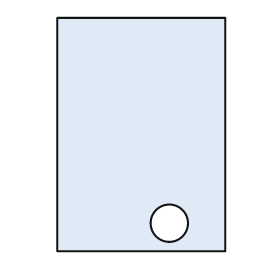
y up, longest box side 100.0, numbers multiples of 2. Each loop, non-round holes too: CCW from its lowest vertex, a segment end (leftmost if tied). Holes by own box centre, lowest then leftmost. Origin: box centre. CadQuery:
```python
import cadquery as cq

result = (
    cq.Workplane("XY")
    .moveTo(-36.0, -50.0)
    .lineTo(36.0, -50.0)
    .lineTo(36.0, 50.0)
    .lineTo(-36.0, 50.0)
    .close()
    .moveTo(12.0, -38.0)
    .circle(8.0)
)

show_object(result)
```